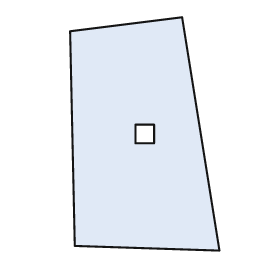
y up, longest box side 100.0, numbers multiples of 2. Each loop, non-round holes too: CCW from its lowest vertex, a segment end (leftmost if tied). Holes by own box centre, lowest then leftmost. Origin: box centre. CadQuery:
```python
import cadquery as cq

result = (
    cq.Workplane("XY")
    .moveTo(32.0, -50.0)
    .lineTo(16.0, 50.0)
    .lineTo(-32.0, 44.0)
    .lineTo(-30.0, -48.0)
    .close()
    .moveTo(-4.0, -4.0)
    .lineTo(4.0, -4.0)
    .lineTo(4.0, 4.0)
    .lineTo(-4.0, 4.0)
    .close()
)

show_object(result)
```